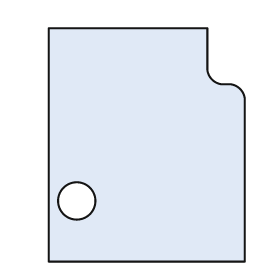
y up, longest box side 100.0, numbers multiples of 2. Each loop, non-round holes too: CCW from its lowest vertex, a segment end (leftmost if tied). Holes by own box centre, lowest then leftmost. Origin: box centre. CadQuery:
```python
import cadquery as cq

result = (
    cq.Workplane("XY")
    .moveTo(-42.0, -50.0)
    .lineTo(42.0, -50.0)
    .lineTo(42.0, 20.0)
    .threePointArc((40.0, 24.0), (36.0, 26.0))
    .lineTo(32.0, 26.0)
    .threePointArc((28.0, 28.0), (26.0, 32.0))
    .lineTo(26.0, 50.0)
    .lineTo(-42.0, 50.0)
    .close()
    .moveTo(-30.0, -24.0)
    .circle(8.0)
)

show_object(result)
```